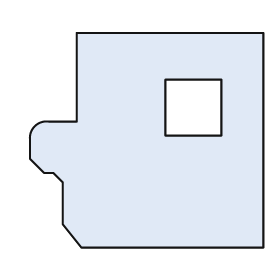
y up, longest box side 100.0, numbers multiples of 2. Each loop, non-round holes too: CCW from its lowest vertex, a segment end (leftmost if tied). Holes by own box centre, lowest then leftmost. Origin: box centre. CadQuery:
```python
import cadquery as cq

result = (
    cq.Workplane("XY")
    .moveTo(-28.0, -46.0)
    .lineTo(50.0, -46.0)
    .lineTo(50.0, 46.0)
    .lineTo(-30.0, 46.0)
    .lineTo(-30.0, 8.0)
    .lineTo(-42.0, 8.0)
    .threePointArc((-48.0, 6.0), (-50.0, 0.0))
    .lineTo(-50.0, -8.0)
    .lineTo(-44.0, -14.0)
    .lineTo(-40.0, -14.0)
    .lineTo(-36.0, -18.0)
    .lineTo(-36.0, -36.0)
    .close()
    .moveTo(8.0, 2.0)
    .lineTo(32.0, 2.0)
    .lineTo(32.0, 26.0)
    .lineTo(8.0, 26.0)
    .close()
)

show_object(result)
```